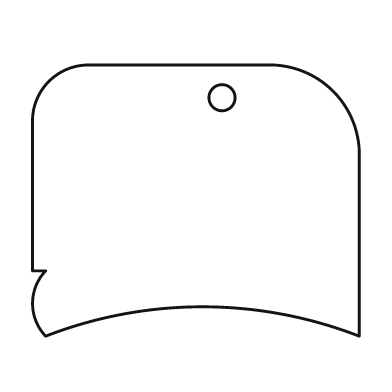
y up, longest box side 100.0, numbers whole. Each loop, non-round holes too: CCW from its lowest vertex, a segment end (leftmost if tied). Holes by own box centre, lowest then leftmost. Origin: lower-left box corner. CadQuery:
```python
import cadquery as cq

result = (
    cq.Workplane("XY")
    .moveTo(4.0, 0.0)
    .threePointArc((52.0, 9.0), (100.0, 0.0))
    .lineTo(100.0, 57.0)
    .threePointArc((92.0, 75.0), (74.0, 83.0))
    .lineTo(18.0, 83.0)
    .threePointArc((5.0, 78.0), (0.0, 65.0))
    .lineTo(0.0, 20.0)
    .lineTo(4.0, 20.0)
    .threePointArc((0.0, 10.0), (4.0, 0.0))
    .close()
    .moveTo(58.0, 73.0)
    .circle(4.0)
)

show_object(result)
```